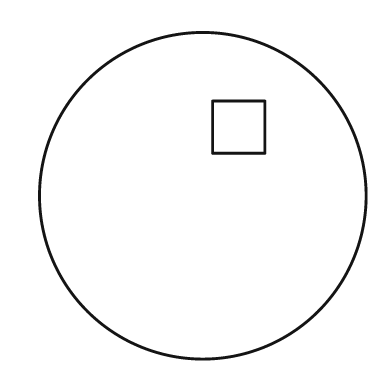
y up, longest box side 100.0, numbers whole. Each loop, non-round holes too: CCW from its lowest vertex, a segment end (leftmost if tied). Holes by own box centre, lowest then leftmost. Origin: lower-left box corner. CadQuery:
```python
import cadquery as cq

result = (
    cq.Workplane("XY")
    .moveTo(50.0, 50.0)
    .circle(50.0)
    .moveTo(53.0, 63.0)
    .lineTo(69.0, 63.0)
    .lineTo(69.0, 79.0)
    .lineTo(53.0, 79.0)
    .close()
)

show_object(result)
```